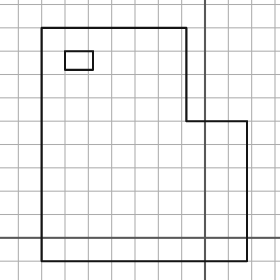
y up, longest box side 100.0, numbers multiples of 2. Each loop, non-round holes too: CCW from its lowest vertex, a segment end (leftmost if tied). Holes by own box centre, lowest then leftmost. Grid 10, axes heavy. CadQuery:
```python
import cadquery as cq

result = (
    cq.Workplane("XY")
    .moveTo(-70.0, -10.0)
    .lineTo(18.0, -10.0)
    .lineTo(18.0, 50.0)
    .lineTo(-8.0, 50.0)
    .lineTo(-8.0, 90.0)
    .lineTo(-70.0, 90.0)
    .close()
    .moveTo(-60.0, 72.0)
    .lineTo(-48.0, 72.0)
    .lineTo(-48.0, 80.0)
    .lineTo(-60.0, 80.0)
    .close()
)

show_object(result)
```